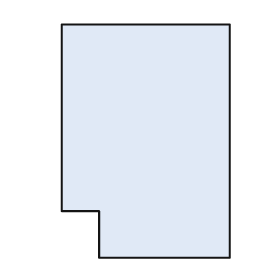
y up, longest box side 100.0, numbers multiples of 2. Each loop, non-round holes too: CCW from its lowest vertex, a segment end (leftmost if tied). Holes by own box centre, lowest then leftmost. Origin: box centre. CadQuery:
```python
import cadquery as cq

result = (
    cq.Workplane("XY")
    .moveTo(-20.0, -50.0)
    .lineTo(36.0, -50.0)
    .lineTo(36.0, 50.0)
    .lineTo(-36.0, 50.0)
    .lineTo(-36.0, -30.0)
    .lineTo(-20.0, -30.0)
    .close()
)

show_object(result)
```